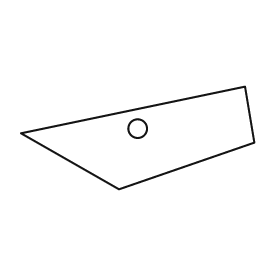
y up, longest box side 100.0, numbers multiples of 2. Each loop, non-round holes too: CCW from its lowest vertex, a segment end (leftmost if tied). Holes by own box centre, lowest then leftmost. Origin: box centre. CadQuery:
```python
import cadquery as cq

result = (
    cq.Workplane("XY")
    .moveTo(-8.0, -22.0)
    .lineTo(50.0, -2.0)
    .lineTo(46.0, 22.0)
    .lineTo(-50.0, 2.0)
    .close()
    .moveTo(0.0, 4.0)
    .circle(4.0)
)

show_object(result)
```